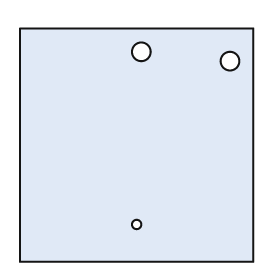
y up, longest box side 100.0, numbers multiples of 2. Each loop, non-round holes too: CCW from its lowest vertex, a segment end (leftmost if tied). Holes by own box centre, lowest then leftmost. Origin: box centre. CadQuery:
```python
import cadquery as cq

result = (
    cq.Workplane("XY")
    .moveTo(-50.0, -50.0)
    .lineTo(50.0, -50.0)
    .lineTo(50.0, 50.0)
    .lineTo(-50.0, 50.0)
    .close()
    .moveTo(0.0, -34.0)
    .circle(2.0)
    .moveTo(40.0, 36.0)
    .circle(4.0)
    .moveTo(2.0, 40.0)
    .circle(4.0)
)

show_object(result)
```